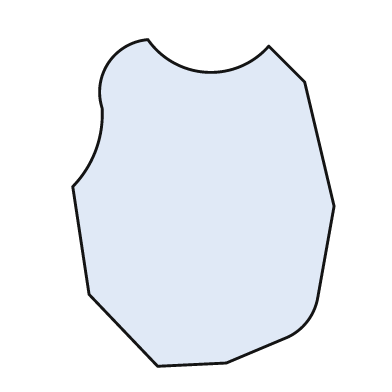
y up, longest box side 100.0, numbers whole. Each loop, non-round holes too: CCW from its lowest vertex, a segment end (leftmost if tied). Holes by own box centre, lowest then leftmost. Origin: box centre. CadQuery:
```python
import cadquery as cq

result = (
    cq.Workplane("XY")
    .moveTo(-14.0, -50.0)
    .lineTo(7.0, -49.0)
    .lineTo(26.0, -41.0)
    .threePointArc((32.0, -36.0), (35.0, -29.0))
    .lineTo(40.0, -1.0)
    .lineTo(31.0, 37.0)
    .lineTo(20.0, 48.0)
    .threePointArc((1.0, 40.0), (-17.0, 50.0))
    .threePointArc((-29.0, 43.0), (-31.0, 29.0))
    .threePointArc((-33.0, 16.0), (-40.0, 5.0))
    .lineTo(-35.0, -28.0)
    .close()
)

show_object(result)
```